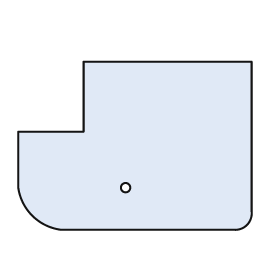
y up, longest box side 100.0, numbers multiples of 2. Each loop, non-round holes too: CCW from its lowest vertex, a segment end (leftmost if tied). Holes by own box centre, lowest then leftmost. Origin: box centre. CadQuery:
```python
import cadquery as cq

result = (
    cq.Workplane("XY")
    .moveTo(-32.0, -36.0)
    .lineTo(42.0, -36.0)
    .threePointArc((48.0, -34.0), (50.0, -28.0))
    .lineTo(50.0, 36.0)
    .lineTo(-22.0, 36.0)
    .lineTo(-22.0, 6.0)
    .lineTo(-50.0, 6.0)
    .lineTo(-50.0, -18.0)
    .threePointArc((-44.0, -30.0), (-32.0, -36.0))
    .close()
    .moveTo(-4.0, -18.0)
    .circle(2.0)
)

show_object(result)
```